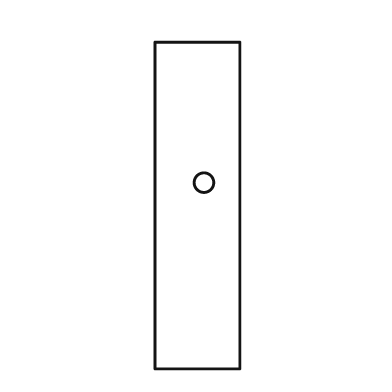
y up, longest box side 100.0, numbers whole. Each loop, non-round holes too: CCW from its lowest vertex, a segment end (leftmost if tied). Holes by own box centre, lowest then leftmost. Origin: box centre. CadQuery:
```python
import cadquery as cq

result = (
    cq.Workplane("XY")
    .moveTo(-13.0, -50.0)
    .lineTo(13.0, -50.0)
    .lineTo(13.0, 50.0)
    .lineTo(-13.0, 50.0)
    .close()
    .moveTo(2.0, 7.0)
    .circle(3.0)
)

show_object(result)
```